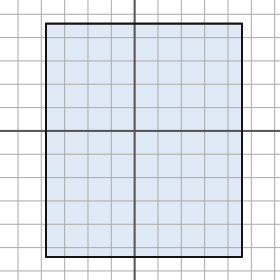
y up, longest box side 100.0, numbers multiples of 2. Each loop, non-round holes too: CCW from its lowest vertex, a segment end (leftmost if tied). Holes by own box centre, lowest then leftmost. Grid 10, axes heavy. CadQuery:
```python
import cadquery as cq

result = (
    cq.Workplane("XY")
    .moveTo(-38.0, -54.0)
    .lineTo(46.0, -54.0)
    .lineTo(46.0, 46.0)
    .lineTo(-38.0, 46.0)
    .close()
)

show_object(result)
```